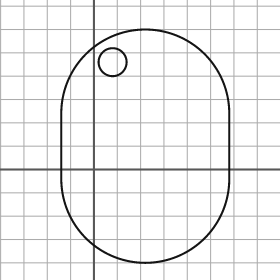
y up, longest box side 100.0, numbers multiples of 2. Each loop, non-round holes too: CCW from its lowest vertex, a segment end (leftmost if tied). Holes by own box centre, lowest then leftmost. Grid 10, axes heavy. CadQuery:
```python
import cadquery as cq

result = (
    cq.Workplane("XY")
    .moveTo(-14.0, -4.0)
    .threePointArc((22.0, -40.0), (58.0, -4.0))
    .lineTo(58.0, 24.0)
    .threePointArc((22.0, 60.0), (-14.0, 24.0))
    .close()
    .moveTo(8.0, 46.0)
    .circle(6.0)
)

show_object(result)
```